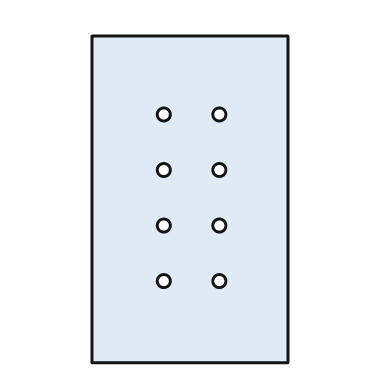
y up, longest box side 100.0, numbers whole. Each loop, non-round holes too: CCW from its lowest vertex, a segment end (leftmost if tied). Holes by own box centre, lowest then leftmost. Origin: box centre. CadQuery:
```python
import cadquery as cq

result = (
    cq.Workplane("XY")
    .moveTo(-30.0, -50.0)
    .lineTo(30.0, -50.0)
    .lineTo(30.0, 50.0)
    .lineTo(-30.0, 50.0)
    .close()
    .moveTo(-8.0, -25.0)
    .circle(2.0)
    .moveTo(9.0, -25.0)
    .circle(2.0)
    .moveTo(-8.0, -8.0)
    .circle(2.0)
    .moveTo(9.0, -8.0)
    .circle(2.0)
    .moveTo(-8.0, 9.0)
    .circle(2.0)
    .moveTo(9.0, 9.0)
    .circle(2.0)
    .moveTo(-8.0, 26.0)
    .circle(2.0)
    .moveTo(9.0, 26.0)
    .circle(2.0)
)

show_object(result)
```